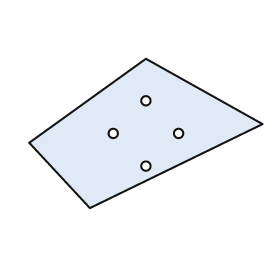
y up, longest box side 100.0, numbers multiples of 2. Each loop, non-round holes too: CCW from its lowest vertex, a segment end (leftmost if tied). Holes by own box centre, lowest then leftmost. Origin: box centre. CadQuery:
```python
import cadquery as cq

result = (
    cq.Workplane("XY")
    .moveTo(-24.0, -32.0)
    .lineTo(50.0, 4.0)
    .lineTo(0.0, 32.0)
    .lineTo(-50.0, -4.0)
    .close()
    .moveTo(0.0, -14.0)
    .circle(2.0)
    .moveTo(-14.0, 0.0)
    .circle(2.0)
    .moveTo(14.0, 0.0)
    .circle(2.0)
    .moveTo(0.0, 14.0)
    .circle(2.0)
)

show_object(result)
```